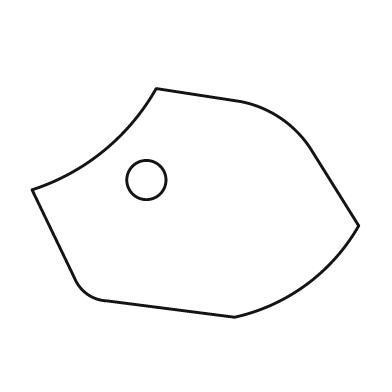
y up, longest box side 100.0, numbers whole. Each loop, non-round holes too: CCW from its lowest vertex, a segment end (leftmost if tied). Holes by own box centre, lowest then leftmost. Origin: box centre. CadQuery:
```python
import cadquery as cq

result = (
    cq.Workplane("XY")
    .moveTo(12.0, -35.0)
    .threePointArc((34.0, -25.0), (50.0, -7.0))
    .lineTo(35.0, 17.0)
    .threePointArc((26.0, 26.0), (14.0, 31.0))
    .lineTo(-12.0, 35.0)
    .threePointArc((-28.0, 16.0), (-50.0, 4.0))
    .lineTo(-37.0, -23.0)
    .threePointArc((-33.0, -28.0), (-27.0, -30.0))
    .close()
    .moveTo(-15.0, 7.0)
    .circle(6.0)
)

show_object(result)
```